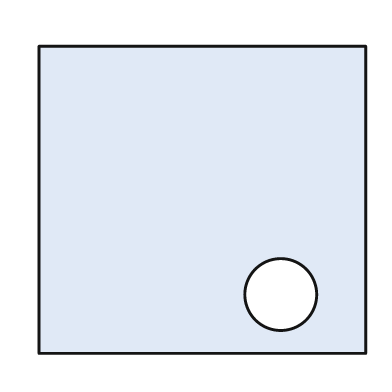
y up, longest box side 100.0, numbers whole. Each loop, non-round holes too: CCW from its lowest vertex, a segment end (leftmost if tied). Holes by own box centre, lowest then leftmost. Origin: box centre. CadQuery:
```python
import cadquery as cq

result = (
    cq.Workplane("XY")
    .moveTo(-50.0, -47.0)
    .lineTo(50.0, -47.0)
    .lineTo(50.0, 47.0)
    .lineTo(-50.0, 47.0)
    .close()
    .moveTo(24.0, -29.0)
    .circle(11.0)
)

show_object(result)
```